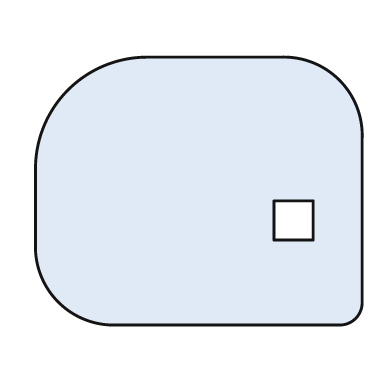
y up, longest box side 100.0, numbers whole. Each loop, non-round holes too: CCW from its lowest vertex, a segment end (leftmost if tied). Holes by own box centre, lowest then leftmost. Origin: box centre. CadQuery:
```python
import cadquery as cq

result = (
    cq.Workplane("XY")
    .moveTo(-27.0, -41.0)
    .lineTo(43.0, -41.0)
    .threePointArc((48.0, -39.0), (50.0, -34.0))
    .lineTo(50.0, 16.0)
    .threePointArc((43.0, 34.0), (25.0, 41.0))
    .lineTo(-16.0, 41.0)
    .threePointArc((-40.0, 31.0), (-50.0, 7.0))
    .lineTo(-50.0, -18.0)
    .threePointArc((-43.0, -34.0), (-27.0, -41.0))
    .close()
    .moveTo(23.0, -15.0)
    .lineTo(35.0, -15.0)
    .lineTo(35.0, -3.0)
    .lineTo(23.0, -3.0)
    .close()
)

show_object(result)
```